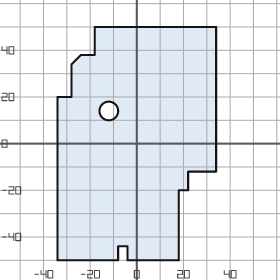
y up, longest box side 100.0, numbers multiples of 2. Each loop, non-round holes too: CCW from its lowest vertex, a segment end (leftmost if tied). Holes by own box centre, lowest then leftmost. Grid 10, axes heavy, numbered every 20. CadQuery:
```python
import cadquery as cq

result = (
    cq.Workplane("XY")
    .moveTo(-34.0, -50.0)
    .lineTo(-8.0, -50.0)
    .lineTo(-8.0, -44.0)
    .lineTo(-4.0, -44.0)
    .lineTo(-4.0, -50.0)
    .lineTo(18.0, -50.0)
    .lineTo(18.0, -20.0)
    .lineTo(22.0, -20.0)
    .lineTo(22.0, -12.0)
    .lineTo(34.0, -12.0)
    .lineTo(34.0, 50.0)
    .lineTo(-18.0, 50.0)
    .lineTo(-18.0, 38.0)
    .lineTo(-24.0, 38.0)
    .lineTo(-28.0, 34.0)
    .lineTo(-28.0, 20.0)
    .lineTo(-34.0, 20.0)
    .close()
    .moveTo(-12.0, 14.0)
    .circle(4.0)
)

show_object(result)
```